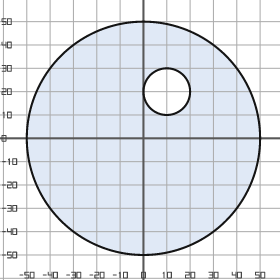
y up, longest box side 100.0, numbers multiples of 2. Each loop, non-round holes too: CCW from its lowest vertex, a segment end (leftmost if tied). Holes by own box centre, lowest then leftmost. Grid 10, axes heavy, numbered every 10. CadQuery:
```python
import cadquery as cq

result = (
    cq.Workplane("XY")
    .moveTo(0.0, 0.0)
    .circle(50.0)
    .moveTo(10.0, 20.0)
    .circle(10.0)
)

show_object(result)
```